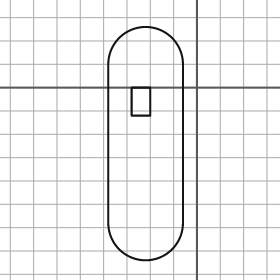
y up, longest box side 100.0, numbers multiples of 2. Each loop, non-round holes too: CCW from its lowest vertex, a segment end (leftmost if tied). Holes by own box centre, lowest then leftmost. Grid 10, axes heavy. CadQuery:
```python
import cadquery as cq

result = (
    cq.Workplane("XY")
    .moveTo(-38.0, -58.0)
    .threePointArc((-22.0, -74.0), (-6.0, -58.0))
    .lineTo(-6.0, 10.0)
    .threePointArc((-22.0, 26.0), (-38.0, 10.0))
    .close()
    .moveTo(-28.0, -12.0)
    .lineTo(-20.0, -12.0)
    .lineTo(-20.0, 0.0)
    .lineTo(-28.0, 0.0)
    .close()
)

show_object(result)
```